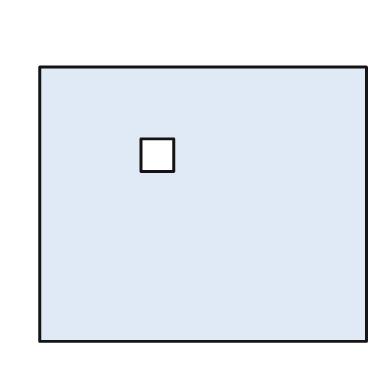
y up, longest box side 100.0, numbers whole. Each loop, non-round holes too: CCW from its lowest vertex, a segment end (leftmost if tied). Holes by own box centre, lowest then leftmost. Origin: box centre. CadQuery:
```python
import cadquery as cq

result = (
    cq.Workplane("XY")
    .moveTo(-50.0, -42.0)
    .lineTo(50.0, -42.0)
    .lineTo(50.0, 42.0)
    .lineTo(-50.0, 42.0)
    .close()
    .moveTo(-19.0, 10.0)
    .lineTo(-9.0, 10.0)
    .lineTo(-9.0, 20.0)
    .lineTo(-19.0, 20.0)
    .close()
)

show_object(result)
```